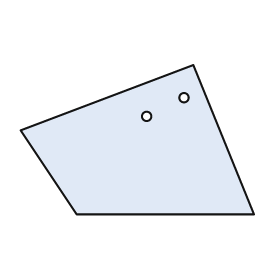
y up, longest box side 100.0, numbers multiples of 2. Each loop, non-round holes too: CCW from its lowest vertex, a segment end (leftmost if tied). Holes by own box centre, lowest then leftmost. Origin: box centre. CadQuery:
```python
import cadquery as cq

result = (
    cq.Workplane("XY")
    .moveTo(-26.0, -32.0)
    .lineTo(50.0, -32.0)
    .lineTo(24.0, 32.0)
    .lineTo(-50.0, 4.0)
    .close()
    .moveTo(4.0, 10.0)
    .circle(2.0)
    .moveTo(20.0, 18.0)
    .circle(2.0)
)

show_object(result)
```